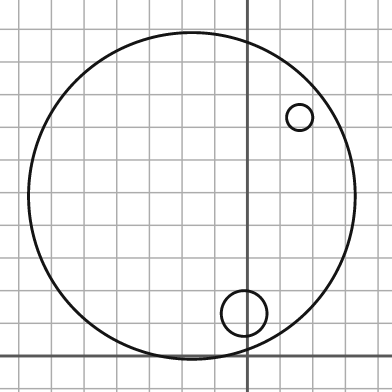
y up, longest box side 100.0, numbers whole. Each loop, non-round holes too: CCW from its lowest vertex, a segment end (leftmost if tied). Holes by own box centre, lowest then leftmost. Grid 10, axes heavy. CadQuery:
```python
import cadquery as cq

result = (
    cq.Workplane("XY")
    .moveTo(-17.0, 49.0)
    .circle(50.0)
    .moveTo(-1.0, 13.0)
    .circle(7.0)
    .moveTo(16.0, 73.0)
    .circle(4.0)
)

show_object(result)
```